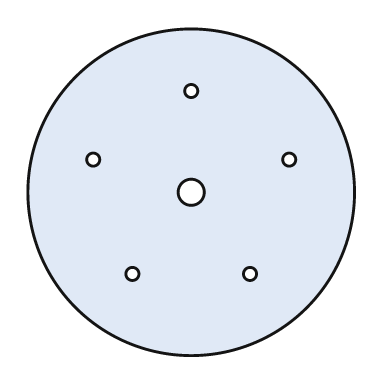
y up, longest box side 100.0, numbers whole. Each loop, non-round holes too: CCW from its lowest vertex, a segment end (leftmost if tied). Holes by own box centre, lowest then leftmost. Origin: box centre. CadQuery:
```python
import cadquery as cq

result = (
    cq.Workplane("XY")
    .moveTo(0.0, 0.0)
    .circle(50.0)
    .moveTo(-18.0, -25.0)
    .circle(2.0)
    .moveTo(18.0, -25.0)
    .circle(2.0)
    .moveTo(0.0, 0.0)
    .circle(4.0)
    .moveTo(-30.0, 10.0)
    .circle(2.0)
    .moveTo(30.0, 10.0)
    .circle(2.0)
    .moveTo(0.0, 31.0)
    .circle(2.0)
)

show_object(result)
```